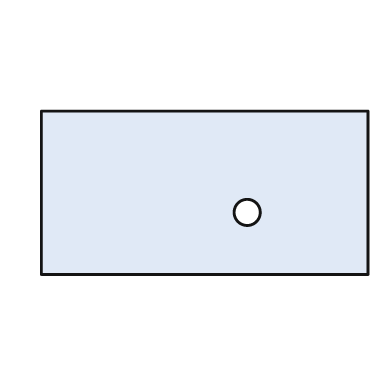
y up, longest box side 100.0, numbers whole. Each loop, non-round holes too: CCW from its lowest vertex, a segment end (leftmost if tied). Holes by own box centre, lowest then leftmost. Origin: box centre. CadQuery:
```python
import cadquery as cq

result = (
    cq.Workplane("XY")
    .moveTo(-50.0, -25.0)
    .lineTo(50.0, -25.0)
    .lineTo(50.0, 25.0)
    .lineTo(-50.0, 25.0)
    .close()
    .moveTo(13.0, -6.0)
    .circle(4.0)
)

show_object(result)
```